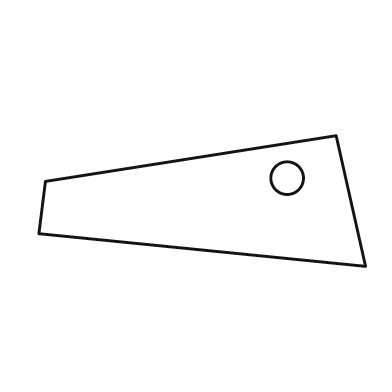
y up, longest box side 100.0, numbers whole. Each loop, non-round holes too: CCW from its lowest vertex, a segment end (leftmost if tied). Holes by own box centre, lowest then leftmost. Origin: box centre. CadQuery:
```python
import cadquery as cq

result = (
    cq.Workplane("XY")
    .moveTo(50.0, -20.0)
    .lineTo(41.0, 20.0)
    .lineTo(-48.0, 6.0)
    .lineTo(-50.0, -10.0)
    .close()
    .moveTo(26.0, 7.0)
    .circle(5.0)
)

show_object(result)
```